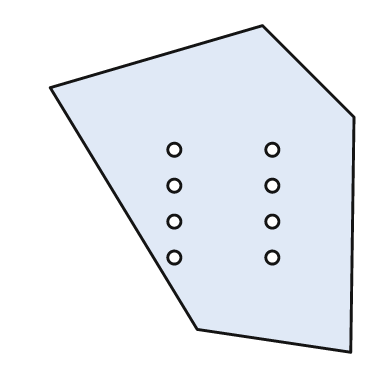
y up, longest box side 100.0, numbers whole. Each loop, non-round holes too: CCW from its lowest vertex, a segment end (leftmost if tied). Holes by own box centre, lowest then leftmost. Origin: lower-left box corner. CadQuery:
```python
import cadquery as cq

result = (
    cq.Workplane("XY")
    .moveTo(92.0, 0.0)
    .lineTo(93.0, 72.0)
    .lineTo(65.0, 100.0)
    .lineTo(0.0, 81.0)
    .lineTo(45.0, 7.0)
    .close()
    .moveTo(38.0, 29.0)
    .circle(2.0)
    .moveTo(68.0, 29.0)
    .circle(2.0)
    .moveTo(38.0, 40.0)
    .circle(2.0)
    .moveTo(68.0, 40.0)
    .circle(2.0)
    .moveTo(38.0, 51.0)
    .circle(2.0)
    .moveTo(68.0, 51.0)
    .circle(2.0)
    .moveTo(38.0, 62.0)
    .circle(2.0)
    .moveTo(68.0, 62.0)
    .circle(2.0)
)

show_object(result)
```